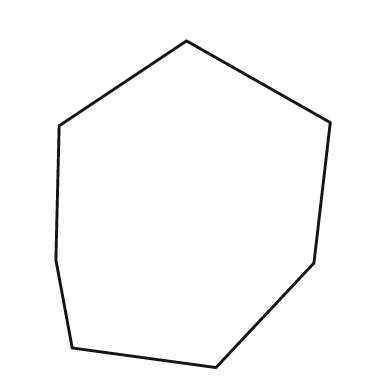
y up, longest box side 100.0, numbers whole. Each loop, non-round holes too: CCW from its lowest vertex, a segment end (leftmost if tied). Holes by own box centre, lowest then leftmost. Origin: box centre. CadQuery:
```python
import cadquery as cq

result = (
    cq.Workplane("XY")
    .moveTo(7.0, -50.0)
    .lineTo(37.0, -18.0)
    .lineTo(42.0, 25.0)
    .lineTo(-2.0, 50.0)
    .lineTo(-41.0, 24.0)
    .lineTo(-42.0, -17.0)
    .lineTo(-37.0, -44.0)
    .close()
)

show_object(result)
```